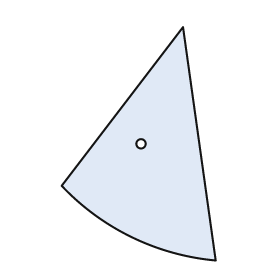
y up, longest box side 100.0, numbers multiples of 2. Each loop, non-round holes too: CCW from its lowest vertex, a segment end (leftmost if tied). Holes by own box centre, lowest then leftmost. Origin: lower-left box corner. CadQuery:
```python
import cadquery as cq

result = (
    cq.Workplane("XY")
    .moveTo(66.0, 0.0)
    .lineTo(52.0, 100.0)
    .lineTo(0.0, 32.0)
    .threePointArc((30.0, 10.0), (66.0, 0.0))
    .close()
    .moveTo(34.0, 50.0)
    .circle(2.0)
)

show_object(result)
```